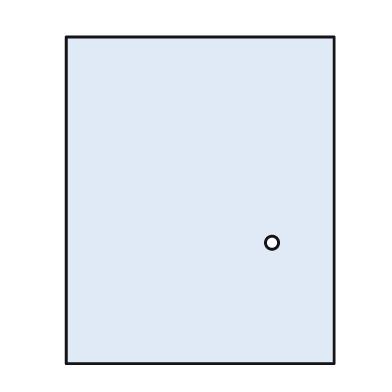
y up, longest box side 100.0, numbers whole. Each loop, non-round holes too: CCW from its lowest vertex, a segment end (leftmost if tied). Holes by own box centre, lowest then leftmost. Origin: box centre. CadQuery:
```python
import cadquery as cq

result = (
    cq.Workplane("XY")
    .moveTo(-41.0, -50.0)
    .lineTo(41.0, -50.0)
    .lineTo(41.0, 50.0)
    .lineTo(-41.0, 50.0)
    .close()
    .moveTo(22.0, -13.0)
    .circle(2.0)
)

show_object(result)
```